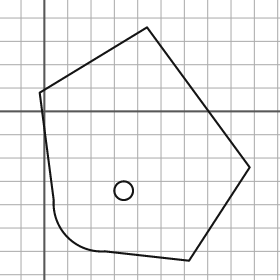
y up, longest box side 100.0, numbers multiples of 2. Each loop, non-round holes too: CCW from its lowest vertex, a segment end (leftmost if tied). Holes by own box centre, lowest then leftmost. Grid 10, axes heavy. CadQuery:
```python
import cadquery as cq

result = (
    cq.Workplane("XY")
    .moveTo(62.0, -64.0)
    .lineTo(88.0, -24.0)
    .lineTo(44.0, 36.0)
    .lineTo(-2.0, 8.0)
    .lineTo(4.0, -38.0)
    .threePointArc((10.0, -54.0), (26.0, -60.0))
    .close()
    .moveTo(34.0, -34.0)
    .circle(4.0)
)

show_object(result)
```